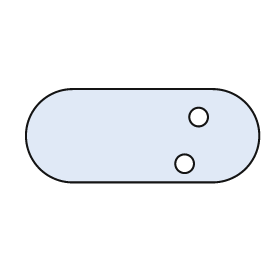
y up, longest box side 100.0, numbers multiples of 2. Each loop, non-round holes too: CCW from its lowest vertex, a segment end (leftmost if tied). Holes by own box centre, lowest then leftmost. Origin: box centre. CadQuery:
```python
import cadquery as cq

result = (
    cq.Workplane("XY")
    .moveTo(-30.0, -20.0)
    .lineTo(30.0, -20.0)
    .threePointArc((50.0, 0.0), (30.0, 20.0))
    .lineTo(-30.0, 20.0)
    .threePointArc((-50.0, 0.0), (-30.0, -20.0))
    .close()
    .moveTo(18.0, -12.0)
    .circle(4.0)
    .moveTo(24.0, 8.0)
    .circle(4.0)
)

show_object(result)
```